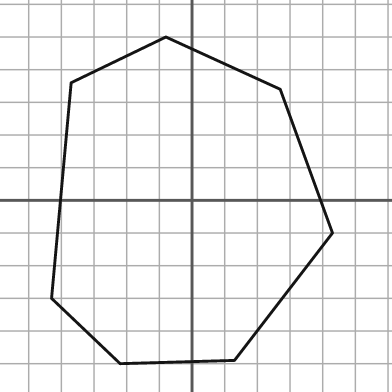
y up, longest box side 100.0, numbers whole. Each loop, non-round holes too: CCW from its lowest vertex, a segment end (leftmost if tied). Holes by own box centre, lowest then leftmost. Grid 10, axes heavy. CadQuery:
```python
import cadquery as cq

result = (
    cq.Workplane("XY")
    .moveTo(-22.0, -50.0)
    .lineTo(13.0, -49.0)
    .lineTo(43.0, -10.0)
    .lineTo(27.0, 34.0)
    .lineTo(-8.0, 50.0)
    .lineTo(-37.0, 36.0)
    .lineTo(-43.0, -30.0)
    .close()
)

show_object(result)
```